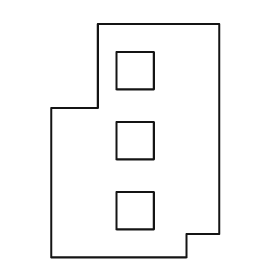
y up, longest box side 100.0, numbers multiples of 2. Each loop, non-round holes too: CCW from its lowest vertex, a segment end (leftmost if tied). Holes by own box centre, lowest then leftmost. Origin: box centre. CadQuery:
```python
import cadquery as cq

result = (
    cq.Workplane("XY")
    .moveTo(-36.0, -50.0)
    .lineTo(22.0, -50.0)
    .lineTo(22.0, -40.0)
    .lineTo(36.0, -40.0)
    .lineTo(36.0, 50.0)
    .lineTo(-16.0, 50.0)
    .lineTo(-16.0, 14.0)
    .lineTo(-36.0, 14.0)
    .close()
    .moveTo(-8.0, -38.0)
    .lineTo(8.0, -38.0)
    .lineTo(8.0, -22.0)
    .lineTo(-8.0, -22.0)
    .close()
    .moveTo(-8.0, -8.0)
    .lineTo(8.0, -8.0)
    .lineTo(8.0, 8.0)
    .lineTo(-8.0, 8.0)
    .close()
    .moveTo(-8.0, 22.0)
    .lineTo(8.0, 22.0)
    .lineTo(8.0, 38.0)
    .lineTo(-8.0, 38.0)
    .close()
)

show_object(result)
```